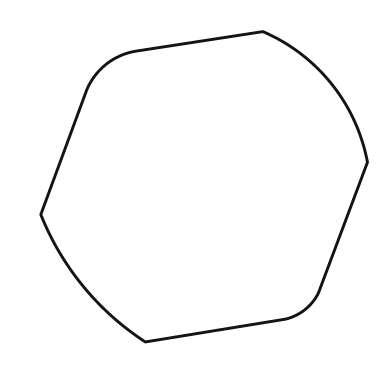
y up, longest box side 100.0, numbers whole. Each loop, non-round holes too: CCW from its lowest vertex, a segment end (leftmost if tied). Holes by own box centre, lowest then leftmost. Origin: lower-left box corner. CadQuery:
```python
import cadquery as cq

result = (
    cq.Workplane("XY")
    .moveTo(32.0, 0.0)
    .lineTo(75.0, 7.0)
    .threePointArc((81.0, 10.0), (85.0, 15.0))
    .lineTo(100.0, 55.0)
    .threePointArc((89.0, 79.0), (68.0, 95.0))
    .lineTo(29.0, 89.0)
    .threePointArc((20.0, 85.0), (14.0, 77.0))
    .lineTo(0.0, 39.0)
    .threePointArc((13.0, 17.0), (32.0, 0.0))
    .close()
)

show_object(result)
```